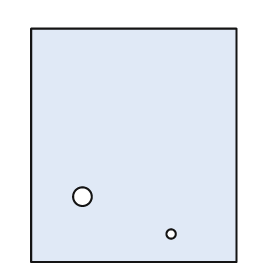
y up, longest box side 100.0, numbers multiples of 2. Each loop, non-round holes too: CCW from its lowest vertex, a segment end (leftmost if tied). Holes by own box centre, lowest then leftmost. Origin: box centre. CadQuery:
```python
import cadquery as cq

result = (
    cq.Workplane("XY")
    .moveTo(-44.0, -50.0)
    .lineTo(44.0, -50.0)
    .lineTo(44.0, 50.0)
    .lineTo(-44.0, 50.0)
    .close()
    .moveTo(16.0, -38.0)
    .circle(2.0)
    .moveTo(-22.0, -22.0)
    .circle(4.0)
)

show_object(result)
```